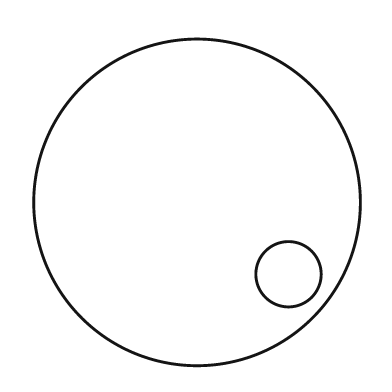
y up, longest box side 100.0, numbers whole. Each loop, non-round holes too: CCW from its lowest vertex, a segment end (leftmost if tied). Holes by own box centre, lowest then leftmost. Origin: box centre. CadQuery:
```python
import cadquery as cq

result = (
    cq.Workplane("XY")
    .moveTo(0.0, 0.0)
    .circle(50.0)
    .moveTo(28.0, -22.0)
    .circle(10.0)
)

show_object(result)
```